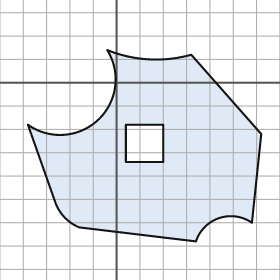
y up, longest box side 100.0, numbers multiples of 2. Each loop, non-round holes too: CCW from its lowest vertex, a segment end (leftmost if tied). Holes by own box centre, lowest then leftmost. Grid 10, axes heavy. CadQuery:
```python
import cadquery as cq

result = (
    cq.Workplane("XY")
    .moveTo(34.0, -68.0)
    .threePointArc((44.0, -58.0), (58.0, -60.0))
    .lineTo(62.0, -22.0)
    .lineTo(32.0, 12.0)
    .threePointArc((14.0, 10.0), (-4.0, 14.0))
    .threePointArc((-8.0, -16.0), (-38.0, -18.0))
    .lineTo(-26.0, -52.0)
    .threePointArc((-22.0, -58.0), (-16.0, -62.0))
    .close()
    .moveTo(4.0, -34.0)
    .lineTo(20.0, -34.0)
    .lineTo(20.0, -18.0)
    .lineTo(4.0, -18.0)
    .close()
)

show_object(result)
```